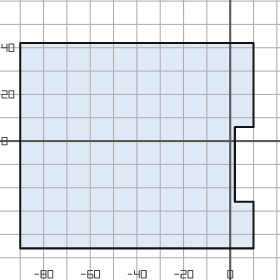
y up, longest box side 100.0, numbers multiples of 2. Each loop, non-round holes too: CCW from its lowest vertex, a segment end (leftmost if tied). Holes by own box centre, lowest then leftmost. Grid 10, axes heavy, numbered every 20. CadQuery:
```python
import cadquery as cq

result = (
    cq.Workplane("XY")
    .moveTo(-90.0, -46.0)
    .lineTo(10.0, -46.0)
    .lineTo(10.0, -26.0)
    .lineTo(2.0, -26.0)
    .lineTo(2.0, 6.0)
    .lineTo(10.0, 6.0)
    .lineTo(10.0, 42.0)
    .lineTo(-90.0, 42.0)
    .close()
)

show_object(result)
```